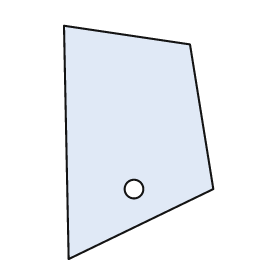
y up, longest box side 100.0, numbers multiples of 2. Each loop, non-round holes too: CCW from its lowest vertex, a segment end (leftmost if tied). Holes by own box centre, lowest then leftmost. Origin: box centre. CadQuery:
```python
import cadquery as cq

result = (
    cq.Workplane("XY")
    .moveTo(-30.0, -50.0)
    .lineTo(32.0, -20.0)
    .lineTo(22.0, 42.0)
    .lineTo(-32.0, 50.0)
    .close()
    .moveTo(-2.0, -20.0)
    .circle(4.0)
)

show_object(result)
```